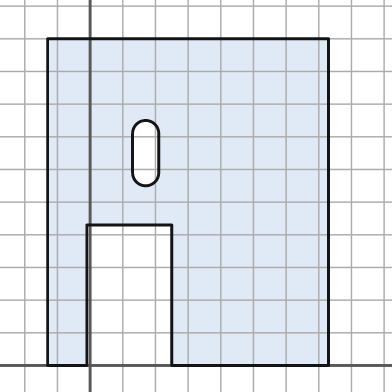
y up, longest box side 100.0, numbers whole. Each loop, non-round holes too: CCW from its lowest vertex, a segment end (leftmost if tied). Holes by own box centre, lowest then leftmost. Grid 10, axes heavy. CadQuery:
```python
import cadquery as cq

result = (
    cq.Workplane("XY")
    .moveTo(-13.0, 0.0)
    .lineTo(-1.0, 0.0)
    .lineTo(-1.0, 43.0)
    .lineTo(25.0, 43.0)
    .lineTo(25.0, 0.0)
    .lineTo(73.0, 0.0)
    .lineTo(73.0, 100.0)
    .lineTo(-13.0, 100.0)
    .close()
    .moveTo(13.0, 59.0)
    .threePointArc((17.0, 55.0), (21.0, 59.0))
    .lineTo(21.0, 71.0)
    .threePointArc((17.0, 75.0), (13.0, 71.0))
    .close()
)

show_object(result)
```